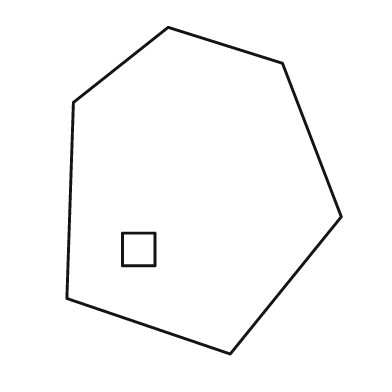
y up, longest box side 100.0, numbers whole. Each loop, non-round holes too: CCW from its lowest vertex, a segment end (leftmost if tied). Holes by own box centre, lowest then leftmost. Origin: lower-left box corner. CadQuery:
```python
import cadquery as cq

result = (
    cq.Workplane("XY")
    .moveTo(50.0, 0.0)
    .lineTo(84.0, 42.0)
    .lineTo(66.0, 89.0)
    .lineTo(31.0, 100.0)
    .lineTo(2.0, 77.0)
    .lineTo(0.0, 17.0)
    .close()
    .moveTo(17.0, 27.0)
    .lineTo(27.0, 27.0)
    .lineTo(27.0, 37.0)
    .lineTo(17.0, 37.0)
    .close()
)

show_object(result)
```